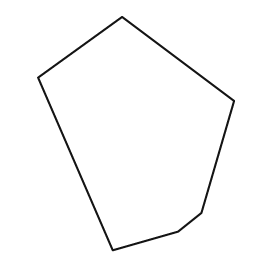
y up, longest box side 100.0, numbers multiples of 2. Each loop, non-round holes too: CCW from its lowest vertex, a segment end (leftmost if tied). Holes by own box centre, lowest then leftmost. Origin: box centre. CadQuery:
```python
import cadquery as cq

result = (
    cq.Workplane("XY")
    .moveTo(-10.0, -50.0)
    .lineTo(18.0, -42.0)
    .lineTo(28.0, -34.0)
    .lineTo(42.0, 14.0)
    .lineTo(-6.0, 50.0)
    .lineTo(-42.0, 24.0)
    .close()
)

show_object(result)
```